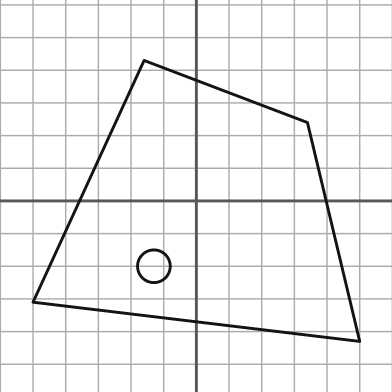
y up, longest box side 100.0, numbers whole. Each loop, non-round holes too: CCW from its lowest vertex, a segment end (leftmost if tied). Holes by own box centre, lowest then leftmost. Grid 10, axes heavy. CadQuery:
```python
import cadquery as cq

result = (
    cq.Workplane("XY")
    .moveTo(50.0, -43.0)
    .lineTo(34.0, 24.0)
    .lineTo(-16.0, 43.0)
    .lineTo(-50.0, -31.0)
    .close()
    .moveTo(-13.0, -20.0)
    .circle(5.0)
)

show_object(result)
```